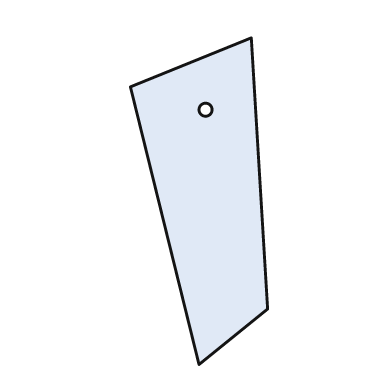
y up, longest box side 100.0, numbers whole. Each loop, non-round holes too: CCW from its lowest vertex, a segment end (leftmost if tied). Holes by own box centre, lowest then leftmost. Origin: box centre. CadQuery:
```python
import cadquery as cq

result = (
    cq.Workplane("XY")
    .moveTo(0.0, -50.0)
    .lineTo(21.0, -33.0)
    .lineTo(16.0, 50.0)
    .lineTo(-21.0, 35.0)
    .close()
    .moveTo(2.0, 28.0)
    .circle(2.0)
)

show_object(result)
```